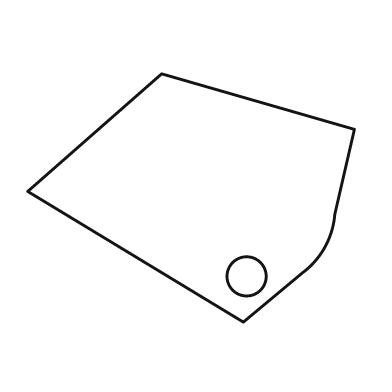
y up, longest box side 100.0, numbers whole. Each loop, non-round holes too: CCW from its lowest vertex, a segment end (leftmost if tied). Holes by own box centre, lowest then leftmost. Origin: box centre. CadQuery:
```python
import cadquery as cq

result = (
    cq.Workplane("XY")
    .moveTo(16.0, -38.0)
    .lineTo(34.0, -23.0)
    .threePointArc((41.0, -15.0), (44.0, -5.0))
    .lineTo(50.0, 21.0)
    .lineTo(-9.0, 38.0)
    .lineTo(-50.0, 2.0)
    .close()
    .moveTo(17.0, -24.0)
    .circle(6.0)
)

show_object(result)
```